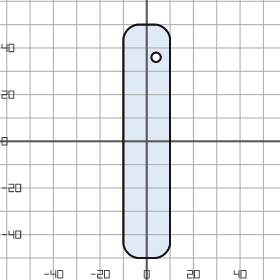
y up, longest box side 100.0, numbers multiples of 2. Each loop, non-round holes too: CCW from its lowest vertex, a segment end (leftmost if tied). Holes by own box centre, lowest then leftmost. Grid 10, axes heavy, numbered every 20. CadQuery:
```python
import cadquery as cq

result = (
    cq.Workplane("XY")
    .moveTo(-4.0, -50.0)
    .lineTo(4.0, -50.0)
    .threePointArc((8.0, -48.0), (10.0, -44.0))
    .lineTo(10.0, 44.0)
    .threePointArc((8.0, 48.0), (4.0, 50.0))
    .lineTo(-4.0, 50.0)
    .threePointArc((-8.0, 48.0), (-10.0, 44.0))
    .lineTo(-10.0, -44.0)
    .threePointArc((-8.0, -48.0), (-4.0, -50.0))
    .close()
    .moveTo(4.0, 36.0)
    .circle(2.0)
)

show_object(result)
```